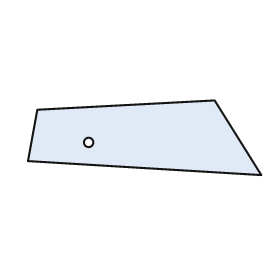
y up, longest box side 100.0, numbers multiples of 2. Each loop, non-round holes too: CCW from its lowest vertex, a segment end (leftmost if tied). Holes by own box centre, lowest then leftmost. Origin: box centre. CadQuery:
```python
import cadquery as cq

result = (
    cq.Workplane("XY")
    .moveTo(50.0, -16.0)
    .lineTo(30.0, 16.0)
    .lineTo(-46.0, 12.0)
    .lineTo(-50.0, -10.0)
    .close()
    .moveTo(-24.0, -2.0)
    .circle(2.0)
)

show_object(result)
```